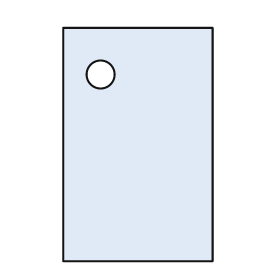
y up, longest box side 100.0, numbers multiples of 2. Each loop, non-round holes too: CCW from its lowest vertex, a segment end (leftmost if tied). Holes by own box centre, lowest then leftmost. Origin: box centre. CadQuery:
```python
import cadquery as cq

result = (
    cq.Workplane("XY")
    .moveTo(-32.0, -50.0)
    .lineTo(32.0, -50.0)
    .lineTo(32.0, 50.0)
    .lineTo(-32.0, 50.0)
    .close()
    .moveTo(-16.0, 30.0)
    .circle(6.0)
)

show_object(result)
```